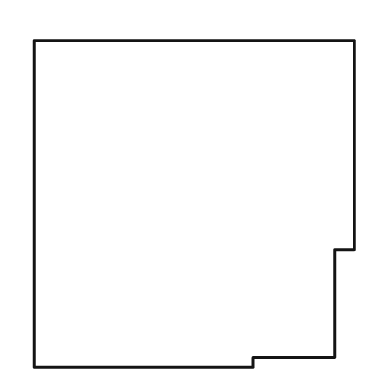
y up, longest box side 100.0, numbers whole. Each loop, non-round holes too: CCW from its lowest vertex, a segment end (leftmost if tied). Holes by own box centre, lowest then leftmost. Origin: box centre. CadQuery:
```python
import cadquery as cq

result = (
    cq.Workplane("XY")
    .moveTo(-49.0, -50.0)
    .lineTo(18.0, -50.0)
    .lineTo(18.0, -47.0)
    .lineTo(43.0, -47.0)
    .lineTo(43.0, -14.0)
    .lineTo(49.0, -14.0)
    .lineTo(49.0, 50.0)
    .lineTo(-49.0, 50.0)
    .close()
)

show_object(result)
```